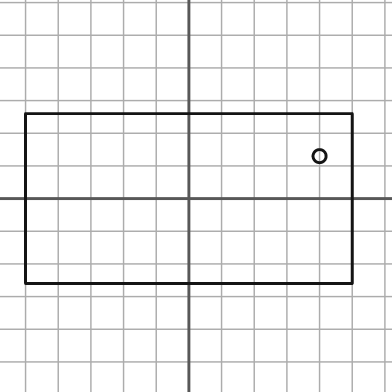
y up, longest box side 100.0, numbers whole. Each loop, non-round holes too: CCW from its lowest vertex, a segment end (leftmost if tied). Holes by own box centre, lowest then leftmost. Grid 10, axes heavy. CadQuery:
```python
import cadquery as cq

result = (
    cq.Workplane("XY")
    .moveTo(-50.0, -26.0)
    .lineTo(50.0, -26.0)
    .lineTo(50.0, 26.0)
    .lineTo(-50.0, 26.0)
    .close()
    .moveTo(40.0, 13.0)
    .circle(2.0)
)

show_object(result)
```